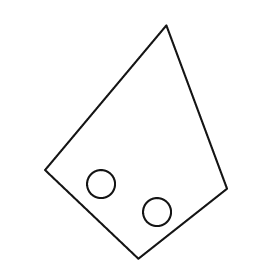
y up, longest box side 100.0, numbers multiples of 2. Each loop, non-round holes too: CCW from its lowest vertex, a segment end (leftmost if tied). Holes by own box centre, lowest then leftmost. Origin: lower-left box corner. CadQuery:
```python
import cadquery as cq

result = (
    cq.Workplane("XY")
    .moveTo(40.0, 0.0)
    .lineTo(78.0, 30.0)
    .lineTo(52.0, 100.0)
    .lineTo(0.0, 38.0)
    .close()
    .moveTo(48.0, 20.0)
    .circle(6.0)
    .moveTo(24.0, 32.0)
    .circle(6.0)
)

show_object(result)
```